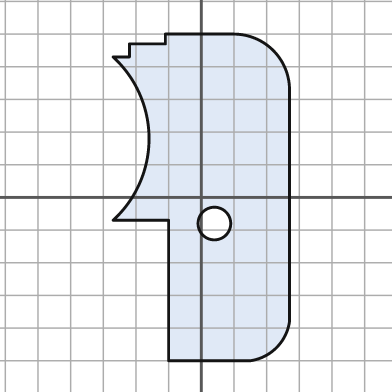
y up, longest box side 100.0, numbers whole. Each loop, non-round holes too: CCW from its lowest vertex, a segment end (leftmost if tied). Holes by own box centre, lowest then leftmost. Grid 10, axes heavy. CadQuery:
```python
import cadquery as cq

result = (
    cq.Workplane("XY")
    .moveTo(-10.0, -50.0)
    .lineTo(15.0, -50.0)
    .threePointArc((23.0, -46.0), (27.0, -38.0))
    .lineTo(27.0, 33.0)
    .threePointArc((22.0, 45.0), (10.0, 50.0))
    .lineTo(-11.0, 50.0)
    .lineTo(-11.0, 47.0)
    .lineTo(-22.0, 47.0)
    .lineTo(-22.0, 43.0)
    .lineTo(-27.0, 43.0)
    .threePointArc((-16.0, 18.0), (-27.0, -7.0))
    .lineTo(-10.0, -7.0)
    .close()
    .moveTo(4.0, -8.0)
    .circle(5.0)
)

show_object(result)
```